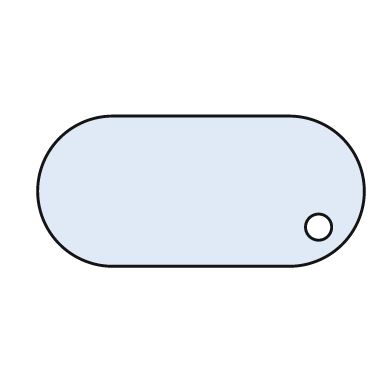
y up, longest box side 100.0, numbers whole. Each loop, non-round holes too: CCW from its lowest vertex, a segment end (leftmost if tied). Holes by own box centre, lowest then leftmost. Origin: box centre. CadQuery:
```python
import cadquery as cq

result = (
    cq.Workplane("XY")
    .moveTo(-27.0, -23.0)
    .lineTo(27.0, -23.0)
    .threePointArc((50.0, 0.0), (27.0, 23.0))
    .lineTo(-27.0, 23.0)
    .threePointArc((-50.0, 0.0), (-27.0, -23.0))
    .close()
    .moveTo(36.0, -11.0)
    .circle(4.0)
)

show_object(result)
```